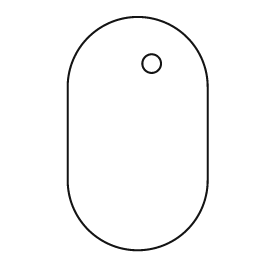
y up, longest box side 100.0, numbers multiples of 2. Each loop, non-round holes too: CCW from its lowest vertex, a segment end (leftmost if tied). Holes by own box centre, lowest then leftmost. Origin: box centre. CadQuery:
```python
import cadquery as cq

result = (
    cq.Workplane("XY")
    .moveTo(-30.0, -20.0)
    .threePointArc((0.0, -50.0), (30.0, -20.0))
    .lineTo(30.0, 20.0)
    .threePointArc((0.0, 50.0), (-30.0, 20.0))
    .close()
    .moveTo(6.0, 30.0)
    .circle(4.0)
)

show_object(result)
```